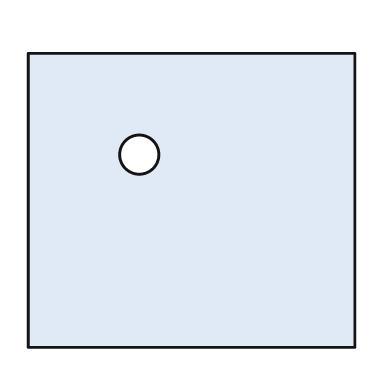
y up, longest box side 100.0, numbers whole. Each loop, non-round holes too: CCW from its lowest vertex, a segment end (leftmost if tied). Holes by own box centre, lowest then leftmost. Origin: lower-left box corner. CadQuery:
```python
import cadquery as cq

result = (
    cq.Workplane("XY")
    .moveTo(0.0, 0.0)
    .lineTo(100.0, 0.0)
    .lineTo(100.0, 90.0)
    .lineTo(0.0, 90.0)
    .close()
    .moveTo(34.0, 59.0)
    .circle(6.0)
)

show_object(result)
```